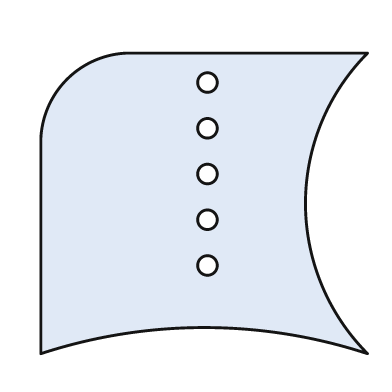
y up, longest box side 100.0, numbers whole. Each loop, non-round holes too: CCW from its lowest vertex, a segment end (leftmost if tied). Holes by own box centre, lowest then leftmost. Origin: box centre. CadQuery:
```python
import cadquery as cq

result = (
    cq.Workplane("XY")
    .moveTo(-50.0, -46.0)
    .threePointArc((0.0, -38.0), (50.0, -46.0))
    .threePointArc((31.0, 0.0), (50.0, 46.0))
    .lineTo(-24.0, 46.0)
    .threePointArc((-42.0, 38.0), (-50.0, 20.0))
    .close()
    .moveTo(1.0, -19.0)
    .circle(3.0)
    .moveTo(1.0, -5.0)
    .circle(3.0)
    .moveTo(1.0, 9.0)
    .circle(3.0)
    .moveTo(1.0, 23.0)
    .circle(3.0)
    .moveTo(1.0, 37.0)
    .circle(3.0)
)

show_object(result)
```